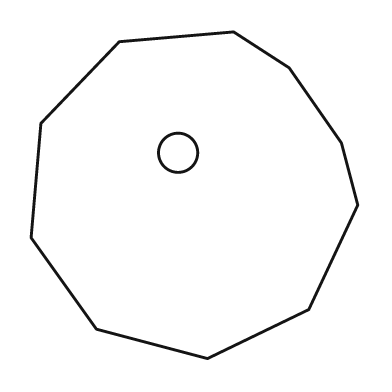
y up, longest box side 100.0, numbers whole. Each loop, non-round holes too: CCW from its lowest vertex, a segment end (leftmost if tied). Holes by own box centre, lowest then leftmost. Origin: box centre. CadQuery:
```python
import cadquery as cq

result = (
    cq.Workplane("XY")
    .moveTo(4.0, -50.0)
    .lineTo(35.0, -35.0)
    .lineTo(50.0, -3.0)
    .lineTo(45.0, 16.0)
    .lineTo(29.0, 39.0)
    .lineTo(12.0, 50.0)
    .lineTo(-23.0, 47.0)
    .lineTo(-47.0, 22.0)
    .lineTo(-50.0, -13.0)
    .lineTo(-30.0, -41.0)
    .close()
    .moveTo(-5.0, 13.0)
    .circle(6.0)
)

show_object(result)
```